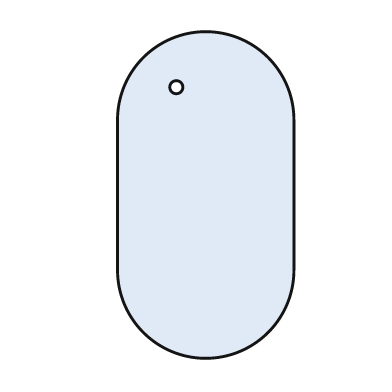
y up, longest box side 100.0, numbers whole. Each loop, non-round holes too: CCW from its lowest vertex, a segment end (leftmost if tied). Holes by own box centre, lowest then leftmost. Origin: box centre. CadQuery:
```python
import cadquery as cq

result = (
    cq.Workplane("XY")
    .moveTo(-27.0, -23.0)
    .threePointArc((0.0, -50.0), (27.0, -23.0))
    .lineTo(27.0, 23.0)
    .threePointArc((0.0, 50.0), (-27.0, 23.0))
    .close()
    .moveTo(-9.0, 33.0)
    .circle(2.0)
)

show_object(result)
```